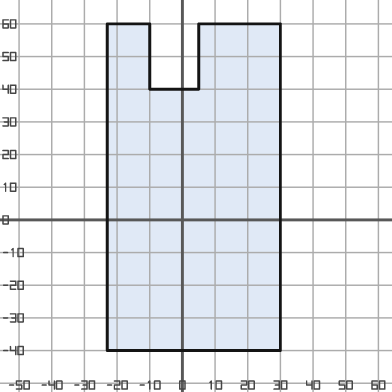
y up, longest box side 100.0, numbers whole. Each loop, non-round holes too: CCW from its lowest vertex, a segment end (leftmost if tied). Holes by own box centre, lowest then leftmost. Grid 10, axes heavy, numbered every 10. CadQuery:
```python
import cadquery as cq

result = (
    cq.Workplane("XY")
    .moveTo(-23.0, -40.0)
    .lineTo(30.0, -40.0)
    .lineTo(30.0, 60.0)
    .lineTo(5.0, 60.0)
    .lineTo(5.0, 40.0)
    .lineTo(-10.0, 40.0)
    .lineTo(-10.0, 60.0)
    .lineTo(-23.0, 60.0)
    .close()
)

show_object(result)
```